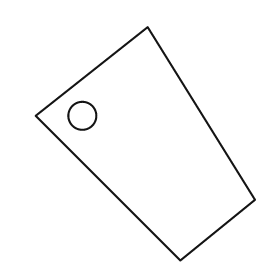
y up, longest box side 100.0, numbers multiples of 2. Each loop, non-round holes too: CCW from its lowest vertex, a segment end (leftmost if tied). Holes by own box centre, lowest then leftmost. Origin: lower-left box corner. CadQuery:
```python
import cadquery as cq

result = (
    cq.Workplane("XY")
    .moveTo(62.0, 0.0)
    .lineTo(94.0, 26.0)
    .lineTo(48.0, 100.0)
    .lineTo(0.0, 62.0)
    .close()
    .moveTo(20.0, 62.0)
    .circle(6.0)
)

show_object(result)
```